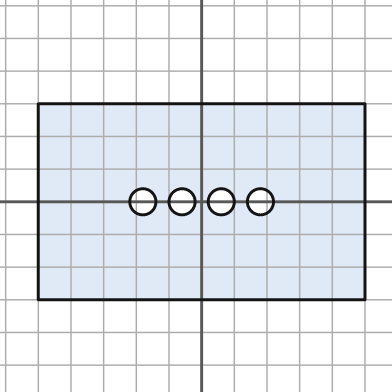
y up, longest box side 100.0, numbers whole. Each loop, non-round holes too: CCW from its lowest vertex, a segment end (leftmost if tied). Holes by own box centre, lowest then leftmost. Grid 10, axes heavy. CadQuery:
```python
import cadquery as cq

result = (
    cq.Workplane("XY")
    .moveTo(-50.0, -30.0)
    .lineTo(50.0, -30.0)
    .lineTo(50.0, 30.0)
    .lineTo(-50.0, 30.0)
    .close()
    .moveTo(-18.0, 0.0)
    .circle(4.0)
    .moveTo(-6.0, 0.0)
    .circle(4.0)
    .moveTo(6.0, 0.0)
    .circle(4.0)
    .moveTo(18.0, 0.0)
    .circle(4.0)
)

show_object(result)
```